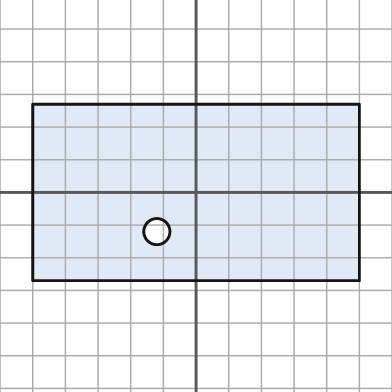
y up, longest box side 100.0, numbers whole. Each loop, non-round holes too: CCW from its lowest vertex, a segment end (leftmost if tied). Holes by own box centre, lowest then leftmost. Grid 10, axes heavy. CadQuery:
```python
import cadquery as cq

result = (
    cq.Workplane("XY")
    .moveTo(-50.0, -27.0)
    .lineTo(50.0, -27.0)
    .lineTo(50.0, 27.0)
    .lineTo(-50.0, 27.0)
    .close()
    .moveTo(-12.0, -12.0)
    .circle(4.0)
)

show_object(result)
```